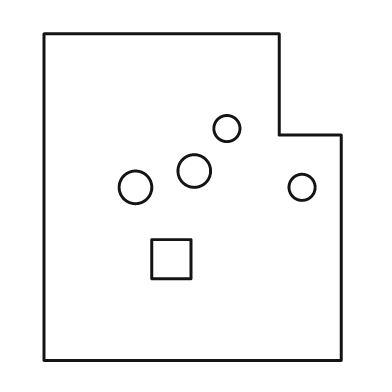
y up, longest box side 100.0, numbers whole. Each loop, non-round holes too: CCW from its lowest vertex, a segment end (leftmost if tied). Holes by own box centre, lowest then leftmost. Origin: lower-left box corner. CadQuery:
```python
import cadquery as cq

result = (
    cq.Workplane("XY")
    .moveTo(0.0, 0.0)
    .lineTo(91.0, 0.0)
    .lineTo(91.0, 69.0)
    .lineTo(72.0, 69.0)
    .lineTo(72.0, 100.0)
    .lineTo(0.0, 100.0)
    .close()
    .moveTo(33.0, 25.0)
    .lineTo(45.0, 25.0)
    .lineTo(45.0, 37.0)
    .lineTo(33.0, 37.0)
    .close()
    .moveTo(28.0, 53.0)
    .circle(5.0)
    .moveTo(79.0, 53.0)
    .circle(4.0)
    .moveTo(46.0, 58.0)
    .circle(5.0)
    .moveTo(56.0, 71.0)
    .circle(4.0)
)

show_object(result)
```